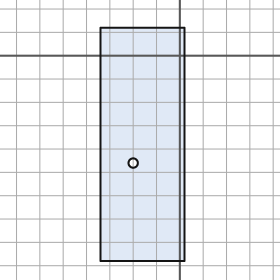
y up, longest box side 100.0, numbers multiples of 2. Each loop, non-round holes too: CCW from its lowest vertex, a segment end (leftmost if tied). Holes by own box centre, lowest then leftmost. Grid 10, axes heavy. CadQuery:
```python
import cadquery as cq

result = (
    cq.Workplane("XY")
    .moveTo(-34.0, -88.0)
    .lineTo(2.0, -88.0)
    .lineTo(2.0, 12.0)
    .lineTo(-34.0, 12.0)
    .close()
    .moveTo(-20.0, -46.0)
    .circle(2.0)
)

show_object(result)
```